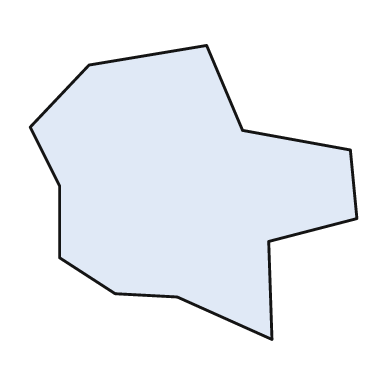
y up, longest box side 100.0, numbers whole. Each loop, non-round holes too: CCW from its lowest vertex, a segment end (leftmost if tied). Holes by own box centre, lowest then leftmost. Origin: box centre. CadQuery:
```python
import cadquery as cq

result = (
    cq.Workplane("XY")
    .moveTo(24.0, -45.0)
    .lineTo(23.0, -15.0)
    .lineTo(50.0, -8.0)
    .lineTo(48.0, 13.0)
    .lineTo(15.0, 19.0)
    .lineTo(4.0, 45.0)
    .lineTo(-32.0, 39.0)
    .lineTo(-50.0, 20.0)
    .lineTo(-41.0, 2.0)
    .lineTo(-41.0, -20.0)
    .lineTo(-24.0, -31.0)
    .lineTo(-5.0, -32.0)
    .close()
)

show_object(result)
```